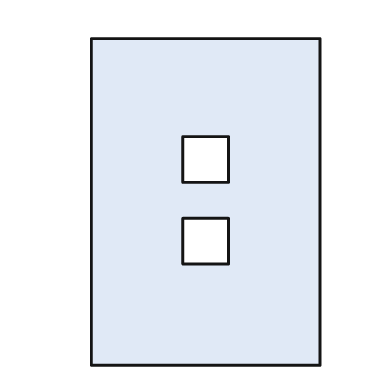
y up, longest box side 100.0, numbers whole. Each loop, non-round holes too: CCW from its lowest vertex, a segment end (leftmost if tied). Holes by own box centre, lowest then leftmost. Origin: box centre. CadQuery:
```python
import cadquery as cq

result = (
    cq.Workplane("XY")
    .moveTo(-35.0, -50.0)
    .lineTo(35.0, -50.0)
    .lineTo(35.0, 50.0)
    .lineTo(-35.0, 50.0)
    .close()
    .moveTo(-7.0, -19.0)
    .lineTo(7.0, -19.0)
    .lineTo(7.0, -5.0)
    .lineTo(-7.0, -5.0)
    .close()
    .moveTo(-7.0, 6.0)
    .lineTo(7.0, 6.0)
    .lineTo(7.0, 20.0)
    .lineTo(-7.0, 20.0)
    .close()
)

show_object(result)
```